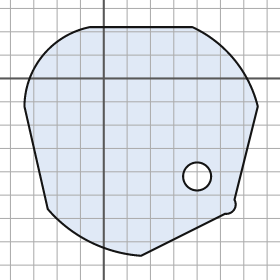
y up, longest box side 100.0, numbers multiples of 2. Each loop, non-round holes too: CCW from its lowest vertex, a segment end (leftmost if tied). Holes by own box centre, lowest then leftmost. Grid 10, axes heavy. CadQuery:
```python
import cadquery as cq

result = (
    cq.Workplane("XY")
    .moveTo(16.0, -76.0)
    .lineTo(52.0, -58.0)
    .threePointArc((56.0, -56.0), (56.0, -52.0))
    .lineTo(66.0, -12.0)
    .threePointArc((56.0, 8.0), (38.0, 22.0))
    .lineTo(-6.0, 22.0)
    .threePointArc((-26.0, 10.0), (-34.0, -12.0))
    .lineTo(-24.0, -56.0)
    .threePointArc((-6.0, -70.0), (16.0, -76.0))
    .close()
    .moveTo(40.0, -42.0)
    .circle(6.0)
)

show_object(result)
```